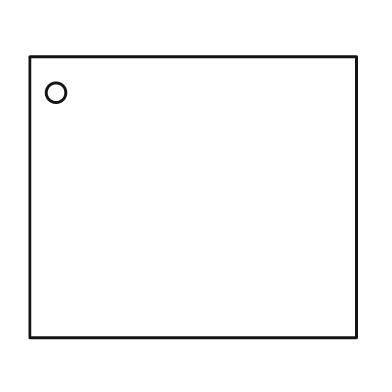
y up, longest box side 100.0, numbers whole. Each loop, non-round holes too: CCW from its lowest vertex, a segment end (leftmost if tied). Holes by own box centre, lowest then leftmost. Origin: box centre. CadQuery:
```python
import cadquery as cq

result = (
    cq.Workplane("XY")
    .moveTo(-50.0, -43.0)
    .lineTo(50.0, -43.0)
    .lineTo(50.0, 43.0)
    .lineTo(-50.0, 43.0)
    .close()
    .moveTo(-42.0, 32.0)
    .circle(3.0)
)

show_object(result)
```